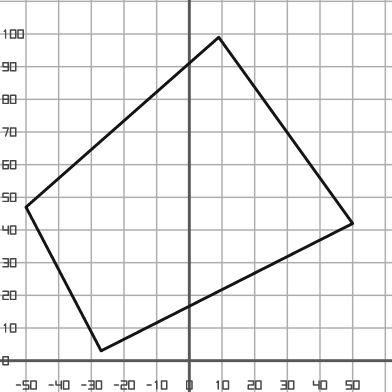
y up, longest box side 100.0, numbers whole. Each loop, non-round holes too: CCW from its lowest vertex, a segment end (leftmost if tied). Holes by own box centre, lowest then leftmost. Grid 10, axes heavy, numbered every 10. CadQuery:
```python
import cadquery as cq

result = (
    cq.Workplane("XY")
    .moveTo(-27.0, 3.0)
    .lineTo(50.0, 42.0)
    .lineTo(9.0, 99.0)
    .lineTo(-50.0, 47.0)
    .close()
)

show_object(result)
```